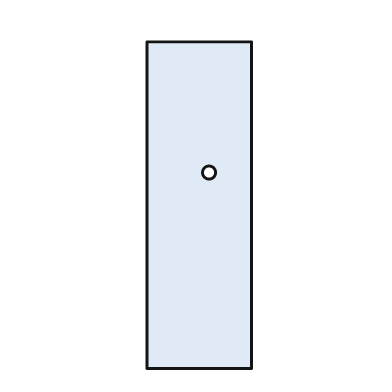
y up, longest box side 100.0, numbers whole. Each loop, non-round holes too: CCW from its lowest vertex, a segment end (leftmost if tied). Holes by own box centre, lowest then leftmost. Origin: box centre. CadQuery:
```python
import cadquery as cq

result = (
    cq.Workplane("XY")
    .moveTo(-16.0, -50.0)
    .lineTo(16.0, -50.0)
    .lineTo(16.0, 50.0)
    .lineTo(-16.0, 50.0)
    .close()
    .moveTo(3.0, 10.0)
    .circle(2.0)
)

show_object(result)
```